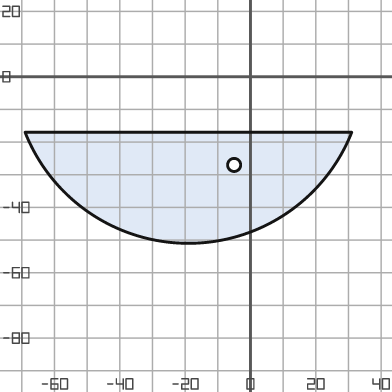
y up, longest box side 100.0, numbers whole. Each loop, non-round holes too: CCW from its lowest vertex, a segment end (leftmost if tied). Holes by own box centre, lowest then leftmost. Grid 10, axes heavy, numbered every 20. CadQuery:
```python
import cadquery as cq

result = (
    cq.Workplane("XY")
    .moveTo(-69.0, -17.0)
    .threePointArc((-19.0, -51.0), (31.0, -17.0))
    .close()
    .moveTo(-5.0, -27.0)
    .circle(2.0)
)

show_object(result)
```